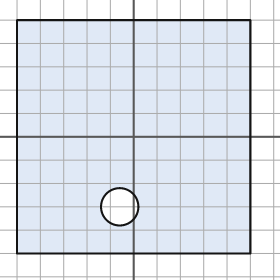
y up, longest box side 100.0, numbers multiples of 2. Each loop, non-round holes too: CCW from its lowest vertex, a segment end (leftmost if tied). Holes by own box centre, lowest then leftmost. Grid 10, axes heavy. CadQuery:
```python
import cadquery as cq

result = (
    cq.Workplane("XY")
    .moveTo(-50.0, -50.0)
    .lineTo(50.0, -50.0)
    .lineTo(50.0, 50.0)
    .lineTo(-50.0, 50.0)
    .close()
    .moveTo(-6.0, -30.0)
    .circle(8.0)
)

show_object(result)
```